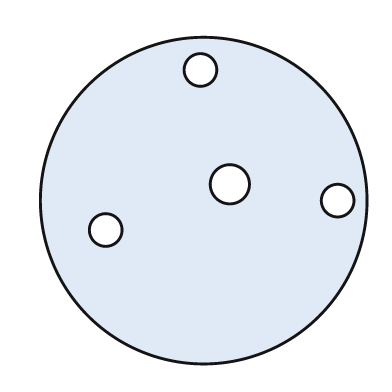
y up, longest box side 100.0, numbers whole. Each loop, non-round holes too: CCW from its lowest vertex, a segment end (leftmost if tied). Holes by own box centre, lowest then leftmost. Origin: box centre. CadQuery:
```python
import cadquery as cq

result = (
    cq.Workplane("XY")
    .moveTo(0.0, 0.0)
    .circle(50.0)
    .moveTo(-30.0, -9.0)
    .circle(5.0)
    .moveTo(41.0, 0.0)
    .circle(5.0)
    .moveTo(8.0, 5.0)
    .circle(6.0)
    .moveTo(-1.0, 40.0)
    .circle(5.0)
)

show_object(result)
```